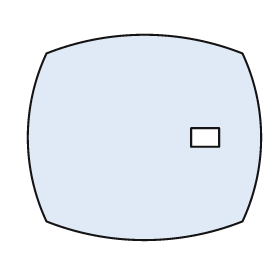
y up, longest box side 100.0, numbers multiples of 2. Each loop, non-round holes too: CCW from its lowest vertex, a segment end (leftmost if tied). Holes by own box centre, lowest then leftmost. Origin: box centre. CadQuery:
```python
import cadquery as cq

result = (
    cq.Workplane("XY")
    .moveTo(-42.0, -36.0)
    .threePointArc((0.0, -44.0), (42.0, -36.0))
    .threePointArc((50.0, 0.0), (42.0, 36.0))
    .threePointArc((0.0, 44.0), (-42.0, 36.0))
    .threePointArc((-50.0, 0.0), (-42.0, -36.0))
    .close()
    .moveTo(20.0, -4.0)
    .lineTo(32.0, -4.0)
    .lineTo(32.0, 4.0)
    .lineTo(20.0, 4.0)
    .close()
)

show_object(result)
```